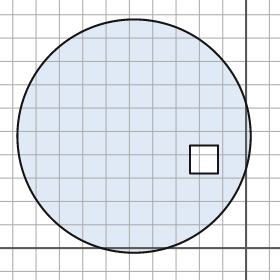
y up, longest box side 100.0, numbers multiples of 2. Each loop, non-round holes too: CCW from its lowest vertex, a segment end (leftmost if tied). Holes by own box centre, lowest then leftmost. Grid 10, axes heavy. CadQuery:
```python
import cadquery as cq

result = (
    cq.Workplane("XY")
    .moveTo(-48.0, 48.0)
    .circle(50.0)
    .moveTo(-24.0, 32.0)
    .lineTo(-12.0, 32.0)
    .lineTo(-12.0, 44.0)
    .lineTo(-24.0, 44.0)
    .close()
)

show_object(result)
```